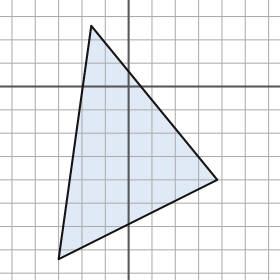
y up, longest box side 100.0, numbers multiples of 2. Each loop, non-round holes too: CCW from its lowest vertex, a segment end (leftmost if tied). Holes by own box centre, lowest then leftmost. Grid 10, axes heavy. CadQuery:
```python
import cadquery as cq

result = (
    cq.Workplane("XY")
    .moveTo(-30.0, -74.0)
    .lineTo(38.0, -40.0)
    .lineTo(-16.0, 26.0)
    .close()
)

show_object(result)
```